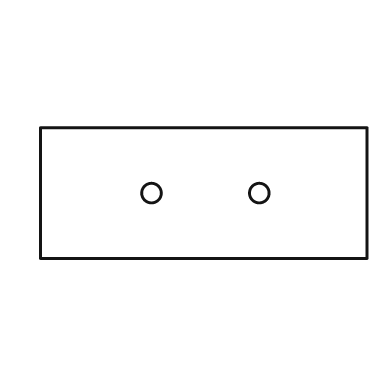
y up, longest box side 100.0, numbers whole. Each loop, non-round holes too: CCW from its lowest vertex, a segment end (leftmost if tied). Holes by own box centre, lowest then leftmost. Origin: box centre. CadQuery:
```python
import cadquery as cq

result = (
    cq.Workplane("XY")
    .moveTo(-50.0, -20.0)
    .lineTo(50.0, -20.0)
    .lineTo(50.0, 20.0)
    .lineTo(-50.0, 20.0)
    .close()
    .moveTo(-16.0, 0.0)
    .circle(3.0)
    .moveTo(17.0, 0.0)
    .circle(3.0)
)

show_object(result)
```